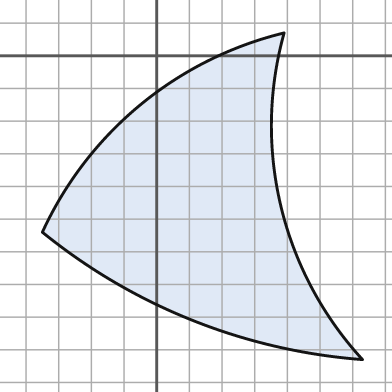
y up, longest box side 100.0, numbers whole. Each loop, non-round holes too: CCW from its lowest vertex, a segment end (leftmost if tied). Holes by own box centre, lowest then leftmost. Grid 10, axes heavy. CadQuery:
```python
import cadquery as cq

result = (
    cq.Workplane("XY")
    .moveTo(63.0, -93.0)
    .threePointArc((38.0, -46.0), (39.0, 7.0))
    .threePointArc((-5.0, -15.0), (-35.0, -54.0))
    .threePointArc((11.0, -81.0), (63.0, -93.0))
    .close()
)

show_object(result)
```